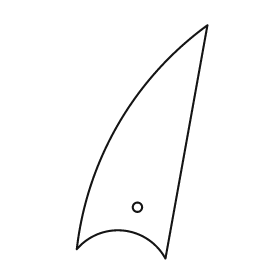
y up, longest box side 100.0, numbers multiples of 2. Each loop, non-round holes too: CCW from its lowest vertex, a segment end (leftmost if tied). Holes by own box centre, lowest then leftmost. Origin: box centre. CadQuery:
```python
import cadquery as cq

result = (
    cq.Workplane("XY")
    .moveTo(10.0, -50.0)
    .lineTo(28.0, 50.0)
    .threePointArc((-10.0, 8.0), (-28.0, -46.0))
    .threePointArc((-8.0, -38.0), (10.0, -50.0))
    .close()
    .moveTo(-2.0, -28.0)
    .circle(2.0)
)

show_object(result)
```